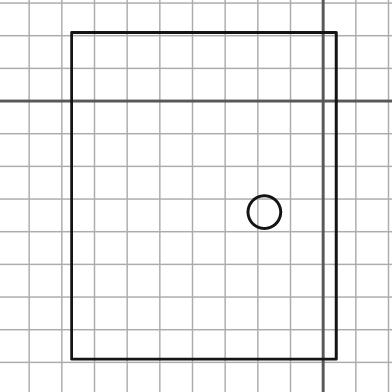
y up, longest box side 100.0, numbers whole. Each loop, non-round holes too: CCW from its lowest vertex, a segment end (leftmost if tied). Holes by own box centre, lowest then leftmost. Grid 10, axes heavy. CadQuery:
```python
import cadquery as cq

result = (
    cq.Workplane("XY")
    .moveTo(-77.0, -79.0)
    .lineTo(4.0, -79.0)
    .lineTo(4.0, 21.0)
    .lineTo(-77.0, 21.0)
    .close()
    .moveTo(-18.0, -34.0)
    .circle(5.0)
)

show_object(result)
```